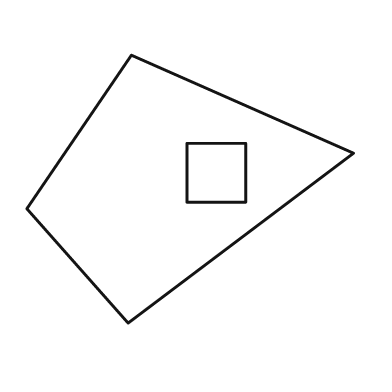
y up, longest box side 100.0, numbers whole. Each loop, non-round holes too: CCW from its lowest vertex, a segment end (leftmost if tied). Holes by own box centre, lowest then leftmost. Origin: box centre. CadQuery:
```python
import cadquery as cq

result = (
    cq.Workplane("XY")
    .moveTo(-19.0, -41.0)
    .lineTo(50.0, 11.0)
    .lineTo(-18.0, 41.0)
    .lineTo(-50.0, -6.0)
    .close()
    .moveTo(-1.0, -4.0)
    .lineTo(17.0, -4.0)
    .lineTo(17.0, 14.0)
    .lineTo(-1.0, 14.0)
    .close()
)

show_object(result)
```